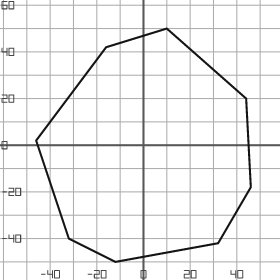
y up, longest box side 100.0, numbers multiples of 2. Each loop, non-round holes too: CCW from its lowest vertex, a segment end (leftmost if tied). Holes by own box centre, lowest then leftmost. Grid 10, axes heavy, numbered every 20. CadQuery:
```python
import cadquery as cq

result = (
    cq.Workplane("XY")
    .moveTo(-12.0, -50.0)
    .lineTo(32.0, -42.0)
    .lineTo(46.0, -18.0)
    .lineTo(44.0, 20.0)
    .lineTo(10.0, 50.0)
    .lineTo(-16.0, 42.0)
    .lineTo(-46.0, 2.0)
    .lineTo(-32.0, -40.0)
    .close()
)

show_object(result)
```